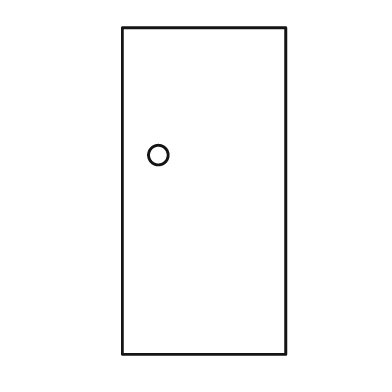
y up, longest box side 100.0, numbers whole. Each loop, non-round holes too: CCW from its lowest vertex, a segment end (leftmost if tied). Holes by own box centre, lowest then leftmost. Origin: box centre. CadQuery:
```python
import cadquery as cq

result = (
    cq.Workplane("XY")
    .moveTo(-25.0, -50.0)
    .lineTo(25.0, -50.0)
    .lineTo(25.0, 50.0)
    .lineTo(-25.0, 50.0)
    .close()
    .moveTo(-14.0, 11.0)
    .circle(3.0)
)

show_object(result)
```